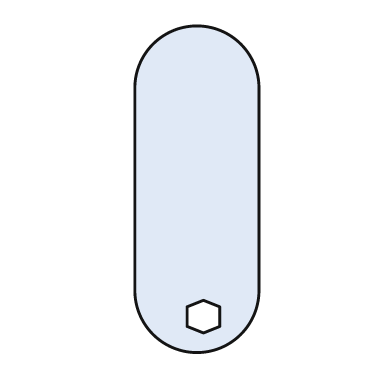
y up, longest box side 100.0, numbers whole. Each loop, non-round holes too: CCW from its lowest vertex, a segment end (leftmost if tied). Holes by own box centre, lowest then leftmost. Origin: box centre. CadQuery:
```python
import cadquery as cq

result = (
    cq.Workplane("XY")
    .moveTo(-19.0, -31.0)
    .threePointArc((0.0, -50.0), (19.0, -31.0))
    .lineTo(19.0, 31.0)
    .threePointArc((0.0, 50.0), (-19.0, 31.0))
    .close()
    .moveTo(2.0, -44.0)
    .lineTo(7.0, -42.0)
    .lineTo(7.0, -36.0)
    .lineTo(2.0, -34.0)
    .lineTo(-3.0, -36.0)
    .lineTo(-3.0, -42.0)
    .close()
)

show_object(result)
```